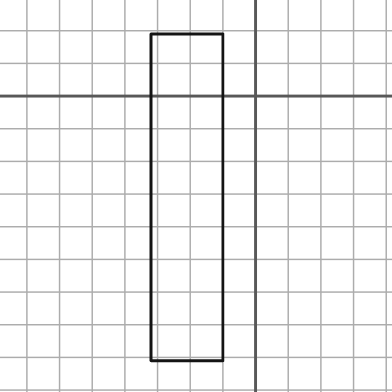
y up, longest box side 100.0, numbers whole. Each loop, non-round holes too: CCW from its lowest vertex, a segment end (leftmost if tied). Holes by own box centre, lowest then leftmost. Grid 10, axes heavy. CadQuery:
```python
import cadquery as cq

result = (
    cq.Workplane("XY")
    .moveTo(-32.0, -81.0)
    .lineTo(-10.0, -81.0)
    .lineTo(-10.0, 19.0)
    .lineTo(-32.0, 19.0)
    .close()
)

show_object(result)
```